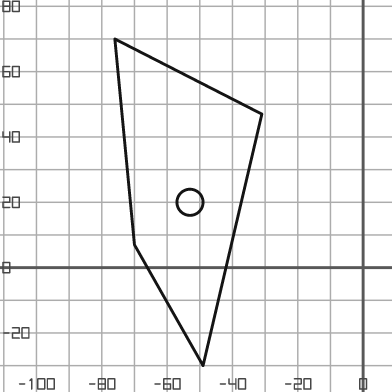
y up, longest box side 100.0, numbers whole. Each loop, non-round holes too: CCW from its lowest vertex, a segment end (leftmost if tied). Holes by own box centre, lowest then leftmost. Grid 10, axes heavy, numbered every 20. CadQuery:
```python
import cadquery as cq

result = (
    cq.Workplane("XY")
    .moveTo(-49.0, -30.0)
    .lineTo(-31.0, 47.0)
    .lineTo(-76.0, 70.0)
    .lineTo(-70.0, 7.0)
    .close()
    .moveTo(-53.0, 20.0)
    .circle(4.0)
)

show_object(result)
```